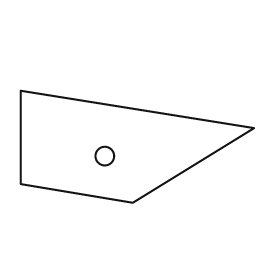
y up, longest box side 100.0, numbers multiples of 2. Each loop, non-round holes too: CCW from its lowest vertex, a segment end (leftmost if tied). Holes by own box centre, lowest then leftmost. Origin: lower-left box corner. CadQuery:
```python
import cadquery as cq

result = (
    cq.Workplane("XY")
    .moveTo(48.0, 0.0)
    .lineTo(100.0, 32.0)
    .lineTo(0.0, 48.0)
    .lineTo(0.0, 8.0)
    .close()
    .moveTo(36.0, 20.0)
    .circle(4.0)
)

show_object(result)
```